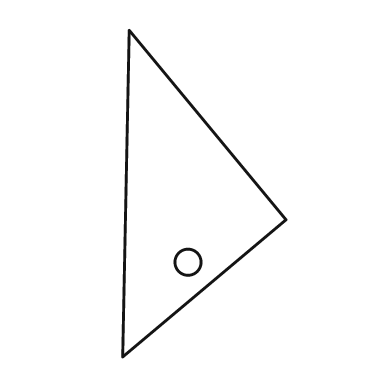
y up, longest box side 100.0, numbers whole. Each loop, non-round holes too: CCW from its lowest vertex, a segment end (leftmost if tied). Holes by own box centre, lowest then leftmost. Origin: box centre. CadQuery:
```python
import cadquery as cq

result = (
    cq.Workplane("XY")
    .moveTo(-25.0, -50.0)
    .lineTo(25.0, -8.0)
    .lineTo(-23.0, 50.0)
    .close()
    .moveTo(-5.0, -21.0)
    .circle(4.0)
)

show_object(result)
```